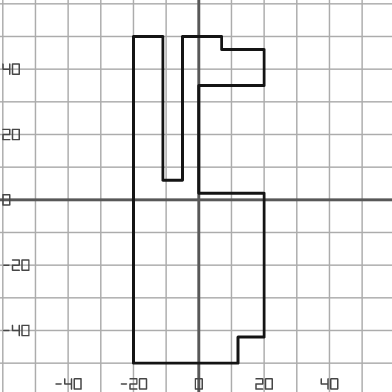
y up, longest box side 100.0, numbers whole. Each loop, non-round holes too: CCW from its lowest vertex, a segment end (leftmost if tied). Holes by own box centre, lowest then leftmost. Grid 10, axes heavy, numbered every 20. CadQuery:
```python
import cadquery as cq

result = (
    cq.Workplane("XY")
    .moveTo(-20.0, -50.0)
    .lineTo(12.0, -50.0)
    .lineTo(12.0, -42.0)
    .lineTo(20.0, -42.0)
    .lineTo(20.0, 2.0)
    .lineTo(0.0, 2.0)
    .lineTo(0.0, 35.0)
    .lineTo(20.0, 35.0)
    .lineTo(20.0, 46.0)
    .lineTo(7.0, 46.0)
    .lineTo(7.0, 50.0)
    .lineTo(-5.0, 50.0)
    .lineTo(-5.0, 6.0)
    .lineTo(-11.0, 6.0)
    .lineTo(-11.0, 50.0)
    .lineTo(-20.0, 50.0)
    .close()
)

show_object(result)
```